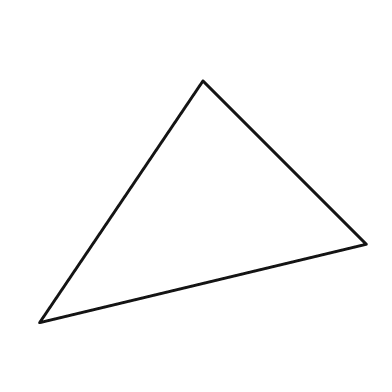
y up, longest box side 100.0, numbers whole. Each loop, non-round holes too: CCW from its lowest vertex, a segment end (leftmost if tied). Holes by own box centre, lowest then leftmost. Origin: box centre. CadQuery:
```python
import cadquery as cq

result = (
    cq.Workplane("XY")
    .moveTo(-50.0, -37.0)
    .lineTo(50.0, -13.0)
    .lineTo(0.0, 37.0)
    .close()
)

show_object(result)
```